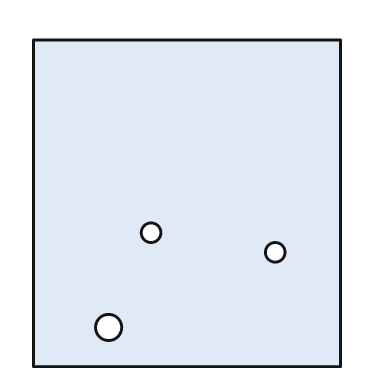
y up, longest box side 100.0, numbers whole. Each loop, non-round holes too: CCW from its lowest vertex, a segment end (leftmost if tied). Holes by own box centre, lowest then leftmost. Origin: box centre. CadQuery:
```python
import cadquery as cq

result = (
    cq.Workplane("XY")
    .moveTo(-47.0, -50.0)
    .lineTo(47.0, -50.0)
    .lineTo(47.0, 50.0)
    .lineTo(-47.0, 50.0)
    .close()
    .moveTo(-24.0, -38.0)
    .circle(4.0)
    .moveTo(27.0, -15.0)
    .circle(3.0)
    .moveTo(-11.0, -9.0)
    .circle(3.0)
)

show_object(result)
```